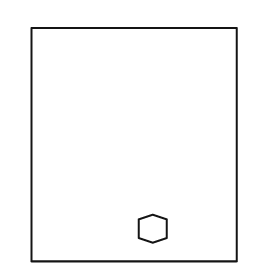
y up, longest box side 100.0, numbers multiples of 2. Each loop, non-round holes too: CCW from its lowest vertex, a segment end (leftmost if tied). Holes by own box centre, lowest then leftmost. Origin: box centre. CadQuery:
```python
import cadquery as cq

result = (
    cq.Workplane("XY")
    .moveTo(-44.0, -50.0)
    .lineTo(44.0, -50.0)
    .lineTo(44.0, 50.0)
    .lineTo(-44.0, 50.0)
    .close()
    .moveTo(8.0, -42.0)
    .lineTo(14.0, -40.0)
    .lineTo(14.0, -32.0)
    .lineTo(8.0, -30.0)
    .lineTo(2.0, -32.0)
    .lineTo(2.0, -40.0)
    .close()
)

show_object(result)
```